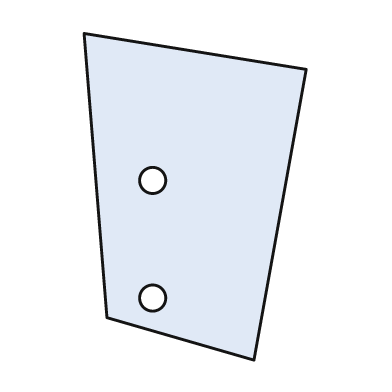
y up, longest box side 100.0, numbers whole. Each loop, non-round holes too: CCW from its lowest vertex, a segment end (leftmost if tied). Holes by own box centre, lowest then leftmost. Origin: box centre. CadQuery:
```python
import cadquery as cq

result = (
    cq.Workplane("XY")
    .moveTo(18.0, -50.0)
    .lineTo(34.0, 39.0)
    .lineTo(-34.0, 50.0)
    .lineTo(-27.0, -37.0)
    .close()
    .moveTo(-13.0, -31.0)
    .circle(4.0)
    .moveTo(-13.0, 5.0)
    .circle(4.0)
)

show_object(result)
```